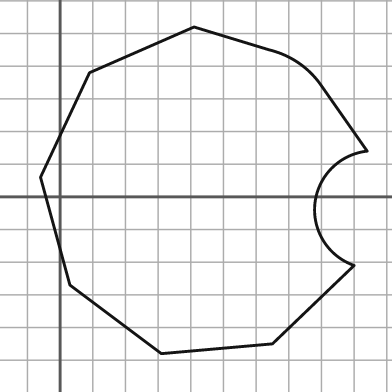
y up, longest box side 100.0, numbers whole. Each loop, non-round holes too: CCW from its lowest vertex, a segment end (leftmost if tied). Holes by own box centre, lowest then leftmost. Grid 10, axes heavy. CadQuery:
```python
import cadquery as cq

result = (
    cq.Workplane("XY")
    .moveTo(31.0, -48.0)
    .lineTo(65.0, -45.0)
    .lineTo(90.0, -21.0)
    .threePointArc((78.0, -2.0), (94.0, 14.0))
    .lineTo(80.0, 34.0)
    .threePointArc((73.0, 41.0), (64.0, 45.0))
    .lineTo(41.0, 52.0)
    .lineTo(9.0, 38.0)
    .lineTo(-6.0, 6.0)
    .lineTo(3.0, -27.0)
    .close()
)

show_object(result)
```